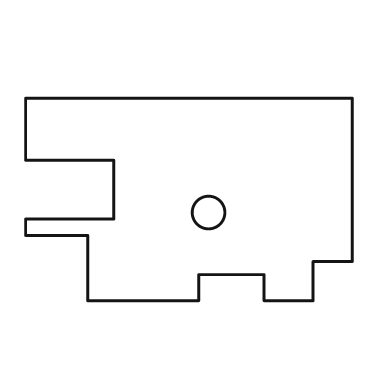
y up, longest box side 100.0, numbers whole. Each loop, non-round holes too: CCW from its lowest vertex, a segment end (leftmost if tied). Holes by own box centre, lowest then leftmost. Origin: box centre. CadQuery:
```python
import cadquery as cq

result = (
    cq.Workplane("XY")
    .moveTo(-31.0, -31.0)
    .lineTo(3.0, -31.0)
    .lineTo(3.0, -23.0)
    .lineTo(23.0, -23.0)
    .lineTo(23.0, -31.0)
    .lineTo(38.0, -31.0)
    .lineTo(38.0, -19.0)
    .lineTo(50.0, -19.0)
    .lineTo(50.0, 31.0)
    .lineTo(-50.0, 31.0)
    .lineTo(-50.0, 12.0)
    .lineTo(-23.0, 12.0)
    .lineTo(-23.0, -6.0)
    .lineTo(-50.0, -6.0)
    .lineTo(-50.0, -11.0)
    .lineTo(-31.0, -11.0)
    .close()
    .moveTo(6.0, -4.0)
    .circle(5.0)
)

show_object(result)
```